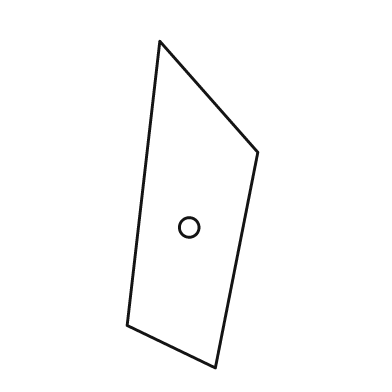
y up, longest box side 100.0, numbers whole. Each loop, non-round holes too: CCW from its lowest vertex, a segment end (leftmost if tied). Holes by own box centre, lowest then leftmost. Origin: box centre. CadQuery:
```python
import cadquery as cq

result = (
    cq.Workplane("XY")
    .moveTo(7.0, -50.0)
    .lineTo(20.0, 16.0)
    .lineTo(-10.0, 50.0)
    .lineTo(-20.0, -37.0)
    .close()
    .moveTo(-1.0, -7.0)
    .circle(3.0)
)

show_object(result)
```